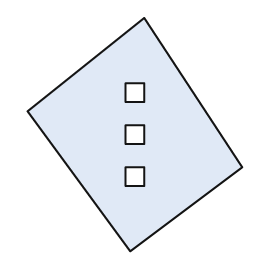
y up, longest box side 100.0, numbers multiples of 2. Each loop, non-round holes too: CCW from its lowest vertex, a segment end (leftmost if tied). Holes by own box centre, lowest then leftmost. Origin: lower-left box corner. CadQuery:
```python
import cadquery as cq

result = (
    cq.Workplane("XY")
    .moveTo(44.0, 0.0)
    .lineTo(92.0, 36.0)
    .lineTo(50.0, 100.0)
    .lineTo(0.0, 60.0)
    .close()
    .moveTo(42.0, 28.0)
    .lineTo(50.0, 28.0)
    .lineTo(50.0, 36.0)
    .lineTo(42.0, 36.0)
    .close()
    .moveTo(42.0, 46.0)
    .lineTo(50.0, 46.0)
    .lineTo(50.0, 54.0)
    .lineTo(42.0, 54.0)
    .close()
    .moveTo(42.0, 64.0)
    .lineTo(50.0, 64.0)
    .lineTo(50.0, 72.0)
    .lineTo(42.0, 72.0)
    .close()
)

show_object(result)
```